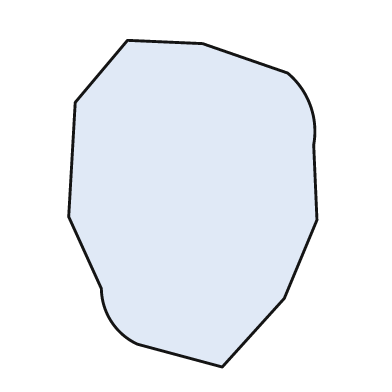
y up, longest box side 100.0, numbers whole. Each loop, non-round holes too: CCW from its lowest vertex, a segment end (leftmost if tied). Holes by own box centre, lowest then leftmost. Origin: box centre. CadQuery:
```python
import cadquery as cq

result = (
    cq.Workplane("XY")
    .moveTo(9.0, -50.0)
    .lineTo(28.0, -29.0)
    .lineTo(38.0, -5.0)
    .lineTo(37.0, 18.0)
    .threePointArc((36.0, 30.0), (29.0, 40.0))
    .lineTo(3.0, 49.0)
    .lineTo(-20.0, 50.0)
    .lineTo(-36.0, 31.0)
    .lineTo(-38.0, -4.0)
    .lineTo(-28.0, -26.0)
    .threePointArc((-25.0, -36.0), (-17.0, -43.0))
    .close()
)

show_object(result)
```